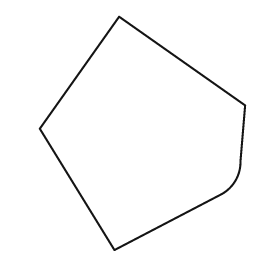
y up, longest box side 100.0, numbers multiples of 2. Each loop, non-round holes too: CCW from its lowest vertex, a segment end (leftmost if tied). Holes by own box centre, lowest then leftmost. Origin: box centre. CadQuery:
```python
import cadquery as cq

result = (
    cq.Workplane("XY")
    .moveTo(-12.0, -50.0)
    .lineTo(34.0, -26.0)
    .threePointArc((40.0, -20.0), (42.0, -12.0))
    .lineTo(44.0, 12.0)
    .lineTo(-10.0, 50.0)
    .lineTo(-44.0, 2.0)
    .close()
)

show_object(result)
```